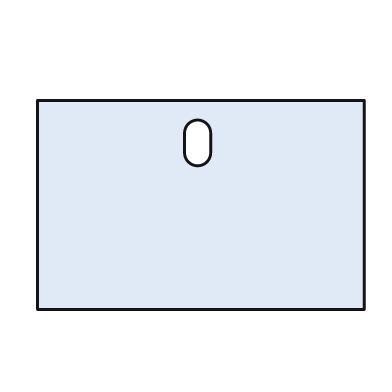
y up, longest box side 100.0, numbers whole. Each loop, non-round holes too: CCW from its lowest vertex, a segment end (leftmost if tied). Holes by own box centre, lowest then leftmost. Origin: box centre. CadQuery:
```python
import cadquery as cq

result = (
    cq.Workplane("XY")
    .moveTo(-50.0, -32.0)
    .lineTo(50.0, -32.0)
    .lineTo(50.0, 32.0)
    .lineTo(-50.0, 32.0)
    .close()
    .moveTo(-5.0, 16.0)
    .threePointArc((-1.0, 12.0), (3.0, 16.0))
    .lineTo(3.0, 22.0)
    .threePointArc((-1.0, 26.0), (-5.0, 22.0))
    .close()
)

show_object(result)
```